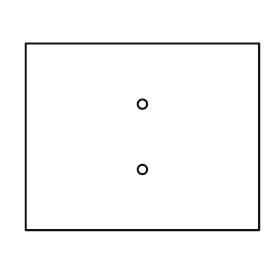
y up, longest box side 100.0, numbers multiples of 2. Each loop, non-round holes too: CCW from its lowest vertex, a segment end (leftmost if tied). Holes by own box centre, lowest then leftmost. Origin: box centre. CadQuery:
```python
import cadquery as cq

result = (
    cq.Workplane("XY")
    .moveTo(-50.0, -40.0)
    .lineTo(50.0, -40.0)
    .lineTo(50.0, 40.0)
    .lineTo(-50.0, 40.0)
    .close()
    .moveTo(0.0, -14.0)
    .circle(2.0)
    .moveTo(0.0, 14.0)
    .circle(2.0)
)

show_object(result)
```